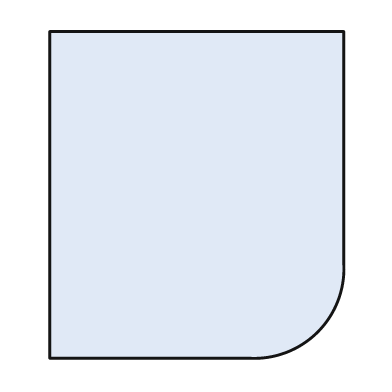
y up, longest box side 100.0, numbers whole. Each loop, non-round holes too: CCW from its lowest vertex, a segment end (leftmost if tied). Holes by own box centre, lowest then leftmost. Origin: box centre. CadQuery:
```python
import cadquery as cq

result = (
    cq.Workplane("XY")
    .moveTo(-45.0, -50.0)
    .lineTo(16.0, -50.0)
    .threePointArc((37.0, -42.0), (45.0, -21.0))
    .lineTo(45.0, 50.0)
    .lineTo(-45.0, 50.0)
    .close()
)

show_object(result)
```